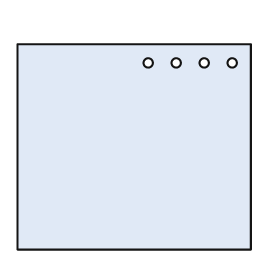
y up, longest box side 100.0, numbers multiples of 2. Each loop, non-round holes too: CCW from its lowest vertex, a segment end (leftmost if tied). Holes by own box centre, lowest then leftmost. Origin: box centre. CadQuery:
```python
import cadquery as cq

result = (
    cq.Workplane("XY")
    .moveTo(-50.0, -44.0)
    .lineTo(50.0, -44.0)
    .lineTo(50.0, 44.0)
    .lineTo(-50.0, 44.0)
    .close()
    .moveTo(6.0, 36.0)
    .circle(2.0)
    .moveTo(18.0, 36.0)
    .circle(2.0)
    .moveTo(30.0, 36.0)
    .circle(2.0)
    .moveTo(42.0, 36.0)
    .circle(2.0)
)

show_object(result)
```